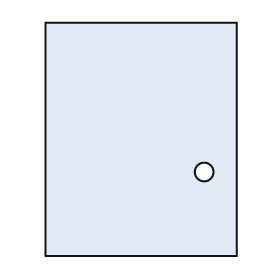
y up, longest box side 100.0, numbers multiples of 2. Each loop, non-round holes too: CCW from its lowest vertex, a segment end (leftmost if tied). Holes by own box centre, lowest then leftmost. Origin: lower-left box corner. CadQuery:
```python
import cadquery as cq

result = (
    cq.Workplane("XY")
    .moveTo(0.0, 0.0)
    .lineTo(82.0, 0.0)
    .lineTo(82.0, 100.0)
    .lineTo(0.0, 100.0)
    .close()
    .moveTo(68.0, 36.0)
    .circle(4.0)
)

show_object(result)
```